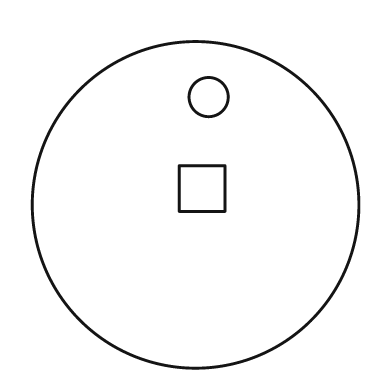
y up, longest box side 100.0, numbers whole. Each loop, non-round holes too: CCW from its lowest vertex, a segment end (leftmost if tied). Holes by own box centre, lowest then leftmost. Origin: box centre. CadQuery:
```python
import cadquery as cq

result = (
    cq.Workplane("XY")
    .moveTo(0.0, 0.0)
    .circle(50.0)
    .moveTo(-5.0, -2.0)
    .lineTo(9.0, -2.0)
    .lineTo(9.0, 12.0)
    .lineTo(-5.0, 12.0)
    .close()
    .moveTo(4.0, 33.0)
    .circle(6.0)
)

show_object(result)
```